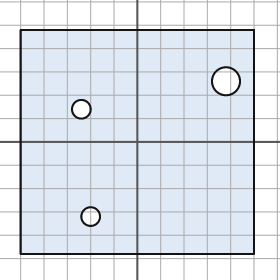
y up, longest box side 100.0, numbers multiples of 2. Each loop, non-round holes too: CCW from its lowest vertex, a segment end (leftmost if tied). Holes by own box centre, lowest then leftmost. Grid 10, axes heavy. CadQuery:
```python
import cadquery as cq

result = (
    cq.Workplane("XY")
    .moveTo(-50.0, -48.0)
    .lineTo(50.0, -48.0)
    .lineTo(50.0, 48.0)
    .lineTo(-50.0, 48.0)
    .close()
    .moveTo(-20.0, -32.0)
    .circle(4.0)
    .moveTo(-24.0, 14.0)
    .circle(4.0)
    .moveTo(38.0, 26.0)
    .circle(6.0)
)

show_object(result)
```